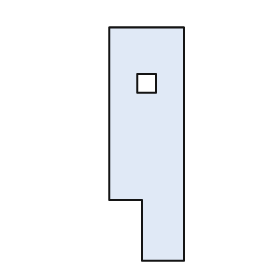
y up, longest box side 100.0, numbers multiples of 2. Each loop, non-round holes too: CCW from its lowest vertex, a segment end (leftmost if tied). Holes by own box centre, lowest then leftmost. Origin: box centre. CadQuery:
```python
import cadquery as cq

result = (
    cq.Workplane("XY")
    .moveTo(-2.0, -50.0)
    .lineTo(16.0, -50.0)
    .lineTo(16.0, 50.0)
    .lineTo(-16.0, 50.0)
    .lineTo(-16.0, -24.0)
    .lineTo(-2.0, -24.0)
    .close()
    .moveTo(-4.0, 22.0)
    .lineTo(4.0, 22.0)
    .lineTo(4.0, 30.0)
    .lineTo(-4.0, 30.0)
    .close()
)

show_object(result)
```